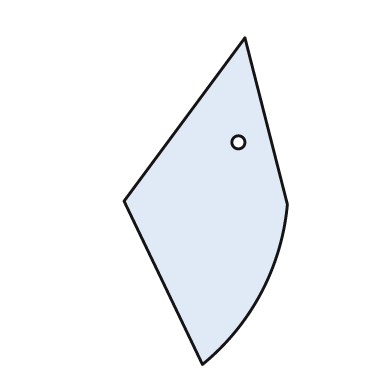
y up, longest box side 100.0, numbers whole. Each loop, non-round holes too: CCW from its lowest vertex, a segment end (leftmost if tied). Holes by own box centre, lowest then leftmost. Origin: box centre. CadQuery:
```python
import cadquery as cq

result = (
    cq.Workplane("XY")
    .moveTo(-1.0, -50.0)
    .threePointArc((17.0, -28.0), (25.0, -1.0))
    .lineTo(12.0, 50.0)
    .lineTo(-25.0, 0.0)
    .close()
    .moveTo(10.0, 18.0)
    .circle(2.0)
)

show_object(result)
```